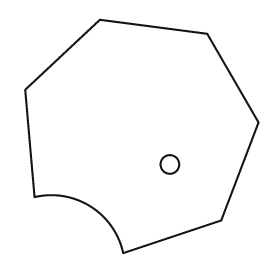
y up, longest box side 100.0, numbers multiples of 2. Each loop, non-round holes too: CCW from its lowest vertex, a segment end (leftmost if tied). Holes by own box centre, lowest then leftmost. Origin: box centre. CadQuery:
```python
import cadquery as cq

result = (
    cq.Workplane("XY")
    .moveTo(-8.0, -50.0)
    .lineTo(34.0, -36.0)
    .lineTo(50.0, 6.0)
    .lineTo(28.0, 44.0)
    .lineTo(-18.0, 50.0)
    .lineTo(-50.0, 20.0)
    .lineTo(-46.0, -26.0)
    .threePointArc((-22.0, -30.0), (-8.0, -50.0))
    .close()
    .moveTo(12.0, -12.0)
    .circle(4.0)
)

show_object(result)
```